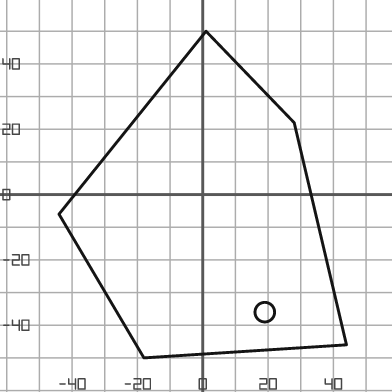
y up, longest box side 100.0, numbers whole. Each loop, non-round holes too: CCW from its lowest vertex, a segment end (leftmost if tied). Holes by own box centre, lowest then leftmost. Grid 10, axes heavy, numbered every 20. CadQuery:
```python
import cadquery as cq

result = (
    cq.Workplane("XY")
    .moveTo(-18.0, -50.0)
    .lineTo(44.0, -46.0)
    .lineTo(28.0, 22.0)
    .lineTo(1.0, 50.0)
    .lineTo(-44.0, -6.0)
    .close()
    .moveTo(19.0, -36.0)
    .circle(3.0)
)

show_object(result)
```